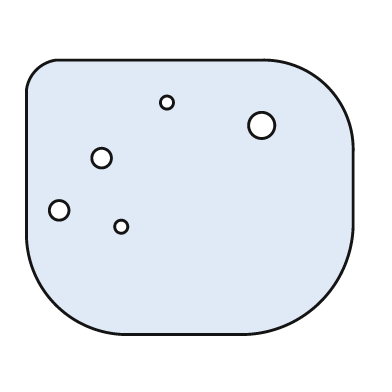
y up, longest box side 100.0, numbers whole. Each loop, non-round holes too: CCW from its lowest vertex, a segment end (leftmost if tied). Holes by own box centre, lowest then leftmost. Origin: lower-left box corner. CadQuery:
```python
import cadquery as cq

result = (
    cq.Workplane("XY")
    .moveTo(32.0, 0.0)
    .lineTo(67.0, 0.0)
    .threePointArc((90.0, 10.0), (100.0, 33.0))
    .lineTo(100.0, 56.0)
    .threePointArc((92.0, 76.0), (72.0, 84.0))
    .lineTo(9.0, 84.0)
    .threePointArc((3.0, 81.0), (0.0, 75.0))
    .lineTo(0.0, 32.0)
    .threePointArc((9.0, 9.0), (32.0, 0.0))
    .close()
    .moveTo(29.0, 33.0)
    .circle(2.0)
    .moveTo(10.0, 38.0)
    .circle(3.0)
    .moveTo(23.0, 54.0)
    .circle(3.0)
    .moveTo(72.0, 64.0)
    .circle(4.0)
    .moveTo(43.0, 71.0)
    .circle(2.0)
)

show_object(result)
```